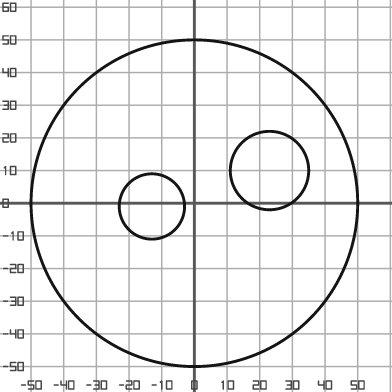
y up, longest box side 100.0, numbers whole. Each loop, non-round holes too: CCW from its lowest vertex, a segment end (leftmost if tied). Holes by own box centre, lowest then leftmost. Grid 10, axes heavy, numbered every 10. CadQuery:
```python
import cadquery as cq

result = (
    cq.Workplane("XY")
    .moveTo(0.0, 0.0)
    .circle(50.0)
    .moveTo(-13.0, -1.0)
    .circle(10.0)
    .moveTo(23.0, 10.0)
    .circle(12.0)
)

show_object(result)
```